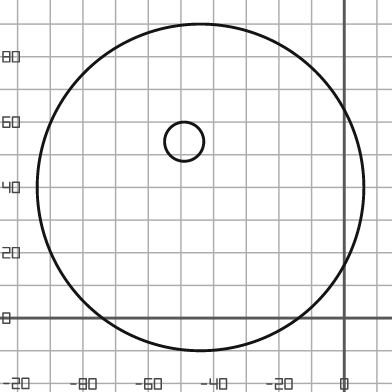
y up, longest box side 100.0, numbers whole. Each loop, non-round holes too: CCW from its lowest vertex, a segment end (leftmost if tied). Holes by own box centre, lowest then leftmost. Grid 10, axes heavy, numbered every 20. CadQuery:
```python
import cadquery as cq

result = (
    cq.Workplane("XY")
    .moveTo(-44.0, 40.0)
    .circle(50.0)
    .moveTo(-49.0, 54.0)
    .circle(6.0)
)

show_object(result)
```